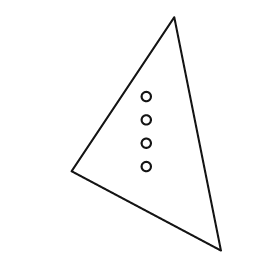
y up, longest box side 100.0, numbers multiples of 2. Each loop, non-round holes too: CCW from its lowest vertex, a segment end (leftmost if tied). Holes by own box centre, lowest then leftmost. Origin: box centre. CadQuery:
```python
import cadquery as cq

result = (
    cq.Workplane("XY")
    .moveTo(32.0, -50.0)
    .lineTo(12.0, 50.0)
    .lineTo(-32.0, -16.0)
    .close()
    .moveTo(0.0, -14.0)
    .circle(2.0)
    .moveTo(0.0, -4.0)
    .circle(2.0)
    .moveTo(0.0, 6.0)
    .circle(2.0)
    .moveTo(0.0, 16.0)
    .circle(2.0)
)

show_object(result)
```